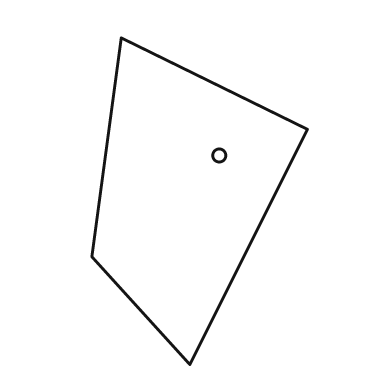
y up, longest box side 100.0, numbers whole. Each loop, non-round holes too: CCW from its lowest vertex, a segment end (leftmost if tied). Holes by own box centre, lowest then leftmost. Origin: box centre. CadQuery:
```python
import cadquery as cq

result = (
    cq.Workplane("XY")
    .moveTo(-3.0, -50.0)
    .lineTo(33.0, 22.0)
    .lineTo(-24.0, 50.0)
    .lineTo(-33.0, -17.0)
    .close()
    .moveTo(6.0, 14.0)
    .circle(2.0)
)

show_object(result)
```